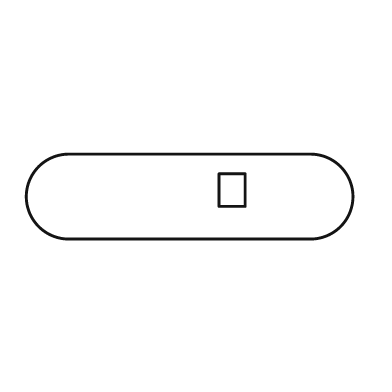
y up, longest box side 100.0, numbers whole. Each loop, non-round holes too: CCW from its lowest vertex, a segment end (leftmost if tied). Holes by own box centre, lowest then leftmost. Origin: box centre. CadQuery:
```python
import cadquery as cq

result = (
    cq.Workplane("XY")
    .moveTo(-37.0, -13.0)
    .lineTo(37.0, -13.0)
    .threePointArc((50.0, 0.0), (37.0, 13.0))
    .lineTo(-37.0, 13.0)
    .threePointArc((-50.0, 0.0), (-37.0, -13.0))
    .close()
    .moveTo(9.0, -3.0)
    .lineTo(17.0, -3.0)
    .lineTo(17.0, 7.0)
    .lineTo(9.0, 7.0)
    .close()
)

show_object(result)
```